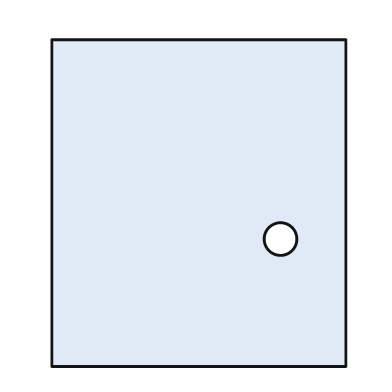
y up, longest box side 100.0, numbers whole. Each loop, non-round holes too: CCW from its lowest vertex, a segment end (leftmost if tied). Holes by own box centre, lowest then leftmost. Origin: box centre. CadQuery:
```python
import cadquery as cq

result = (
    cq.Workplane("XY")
    .moveTo(-45.0, -50.0)
    .lineTo(45.0, -50.0)
    .lineTo(45.0, 50.0)
    .lineTo(-45.0, 50.0)
    .close()
    .moveTo(25.0, -11.0)
    .circle(5.0)
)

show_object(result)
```